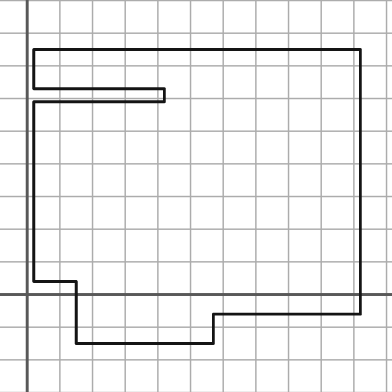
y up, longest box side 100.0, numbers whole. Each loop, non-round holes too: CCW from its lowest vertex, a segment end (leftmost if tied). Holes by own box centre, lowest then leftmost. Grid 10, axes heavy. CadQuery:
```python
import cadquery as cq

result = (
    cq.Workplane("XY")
    .moveTo(15.0, -15.0)
    .lineTo(57.0, -15.0)
    .lineTo(57.0, -6.0)
    .lineTo(102.0, -6.0)
    .lineTo(102.0, 75.0)
    .lineTo(2.0, 75.0)
    .lineTo(2.0, 63.0)
    .lineTo(42.0, 63.0)
    .lineTo(42.0, 59.0)
    .lineTo(2.0, 59.0)
    .lineTo(2.0, 4.0)
    .lineTo(15.0, 4.0)
    .close()
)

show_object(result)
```